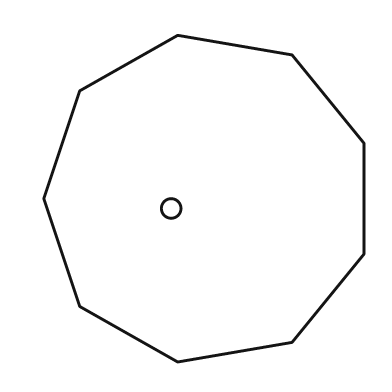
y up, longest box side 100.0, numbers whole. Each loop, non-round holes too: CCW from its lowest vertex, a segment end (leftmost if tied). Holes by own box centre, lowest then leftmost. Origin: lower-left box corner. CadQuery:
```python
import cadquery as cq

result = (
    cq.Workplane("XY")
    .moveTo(41.0, 0.0)
    .lineTo(76.0, 6.0)
    .lineTo(98.0, 33.0)
    .lineTo(98.0, 67.0)
    .lineTo(76.0, 94.0)
    .lineTo(41.0, 100.0)
    .lineTo(11.0, 83.0)
    .lineTo(0.0, 50.0)
    .lineTo(11.0, 17.0)
    .close()
    .moveTo(39.0, 47.0)
    .circle(3.0)
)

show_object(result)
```